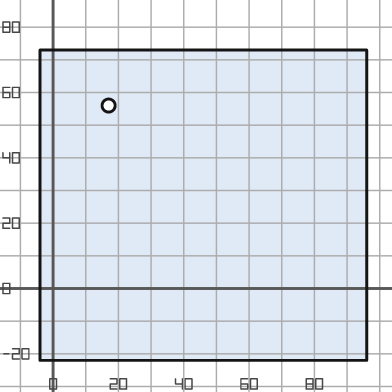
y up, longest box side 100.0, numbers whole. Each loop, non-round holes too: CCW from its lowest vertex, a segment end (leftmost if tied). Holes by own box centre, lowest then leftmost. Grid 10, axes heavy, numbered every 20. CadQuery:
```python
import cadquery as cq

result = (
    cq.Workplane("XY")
    .moveTo(-4.0, -22.0)
    .lineTo(96.0, -22.0)
    .lineTo(96.0, 73.0)
    .lineTo(-4.0, 73.0)
    .close()
    .moveTo(17.0, 56.0)
    .circle(2.0)
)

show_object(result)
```